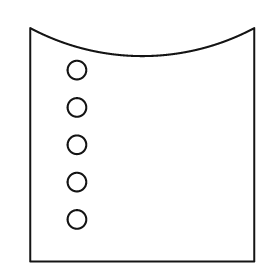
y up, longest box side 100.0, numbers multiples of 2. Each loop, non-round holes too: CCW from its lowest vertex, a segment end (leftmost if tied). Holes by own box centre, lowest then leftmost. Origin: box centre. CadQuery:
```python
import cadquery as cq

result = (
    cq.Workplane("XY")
    .moveTo(-48.0, -50.0)
    .lineTo(48.0, -50.0)
    .lineTo(48.0, 50.0)
    .threePointArc((0.0, 38.0), (-48.0, 50.0))
    .close()
    .moveTo(-28.0, -32.0)
    .circle(4.0)
    .moveTo(-28.0, -16.0)
    .circle(4.0)
    .moveTo(-28.0, 0.0)
    .circle(4.0)
    .moveTo(-28.0, 16.0)
    .circle(4.0)
    .moveTo(-28.0, 32.0)
    .circle(4.0)
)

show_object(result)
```